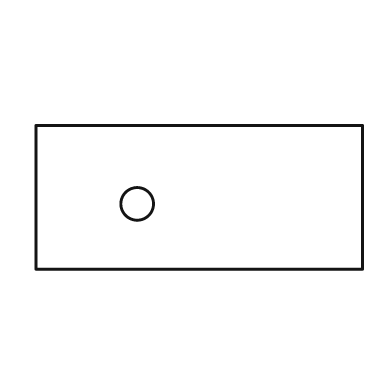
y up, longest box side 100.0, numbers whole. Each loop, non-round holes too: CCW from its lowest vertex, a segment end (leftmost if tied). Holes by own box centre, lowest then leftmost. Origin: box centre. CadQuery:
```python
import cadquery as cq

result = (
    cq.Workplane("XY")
    .moveTo(-50.0, -22.0)
    .lineTo(50.0, -22.0)
    .lineTo(50.0, 22.0)
    .lineTo(-50.0, 22.0)
    .close()
    .moveTo(-19.0, -2.0)
    .circle(5.0)
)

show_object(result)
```